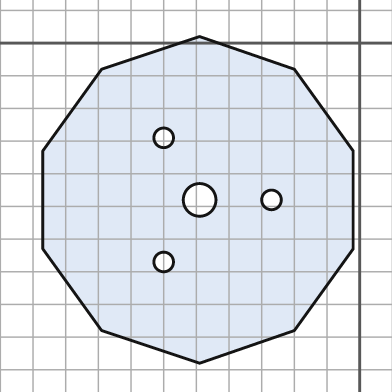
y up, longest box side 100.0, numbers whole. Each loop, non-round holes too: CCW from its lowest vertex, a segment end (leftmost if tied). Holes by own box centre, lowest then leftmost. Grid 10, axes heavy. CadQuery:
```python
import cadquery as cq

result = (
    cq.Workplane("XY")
    .moveTo(-49.0, -98.0)
    .lineTo(-20.0, -88.0)
    .lineTo(-2.0, -63.0)
    .lineTo(-2.0, -33.0)
    .lineTo(-20.0, -8.0)
    .lineTo(-49.0, 2.0)
    .lineTo(-79.0, -8.0)
    .lineTo(-97.0, -33.0)
    .lineTo(-97.0, -63.0)
    .lineTo(-79.0, -88.0)
    .close()
    .moveTo(-60.0, -67.0)
    .circle(3.0)
    .moveTo(-49.0, -48.0)
    .circle(5.0)
    .moveTo(-27.0, -48.0)
    .circle(3.0)
    .moveTo(-60.0, -29.0)
    .circle(3.0)
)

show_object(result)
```